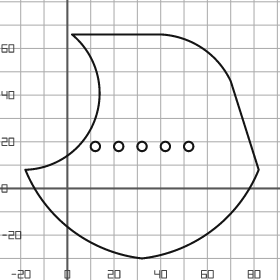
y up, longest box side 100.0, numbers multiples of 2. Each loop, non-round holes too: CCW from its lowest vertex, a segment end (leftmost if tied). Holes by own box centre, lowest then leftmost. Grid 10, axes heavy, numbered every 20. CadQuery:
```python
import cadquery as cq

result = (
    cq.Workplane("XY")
    .moveTo(32.0, -30.0)
    .threePointArc((62.0, -18.0), (82.0, 8.0))
    .lineTo(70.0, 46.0)
    .threePointArc((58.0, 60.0), (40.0, 66.0))
    .lineTo(2.0, 66.0)
    .threePointArc((12.0, 30.0), (-18.0, 8.0))
    .threePointArc((2.0, -18.0), (32.0, -30.0))
    .close()
    .moveTo(12.0, 18.0)
    .circle(2.0)
    .moveTo(22.0, 18.0)
    .circle(2.0)
    .moveTo(32.0, 18.0)
    .circle(2.0)
    .moveTo(42.0, 18.0)
    .circle(2.0)
    .moveTo(52.0, 18.0)
    .circle(2.0)
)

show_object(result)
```